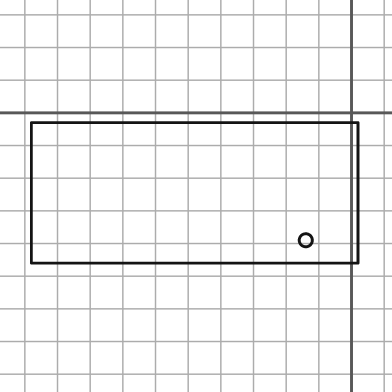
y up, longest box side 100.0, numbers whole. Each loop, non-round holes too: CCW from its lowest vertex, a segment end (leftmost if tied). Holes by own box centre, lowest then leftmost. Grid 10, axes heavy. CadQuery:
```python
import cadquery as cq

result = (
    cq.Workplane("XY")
    .moveTo(-98.0, -46.0)
    .lineTo(2.0, -46.0)
    .lineTo(2.0, -3.0)
    .lineTo(-98.0, -3.0)
    .close()
    .moveTo(-14.0, -39.0)
    .circle(2.0)
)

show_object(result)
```